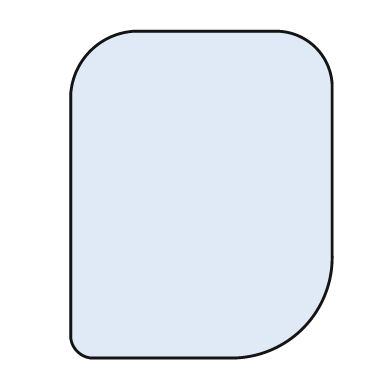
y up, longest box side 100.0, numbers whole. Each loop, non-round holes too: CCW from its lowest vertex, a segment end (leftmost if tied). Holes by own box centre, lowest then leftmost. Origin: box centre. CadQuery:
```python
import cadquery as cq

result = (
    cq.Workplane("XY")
    .moveTo(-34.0, -50.0)
    .lineTo(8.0, -50.0)
    .threePointArc((31.0, -41.0), (40.0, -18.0))
    .lineTo(40.0, 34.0)
    .threePointArc((35.0, 45.0), (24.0, 50.0))
    .lineTo(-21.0, 50.0)
    .threePointArc((-34.0, 44.0), (-40.0, 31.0))
    .lineTo(-40.0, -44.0)
    .threePointArc((-38.0, -48.0), (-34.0, -50.0))
    .close()
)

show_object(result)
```